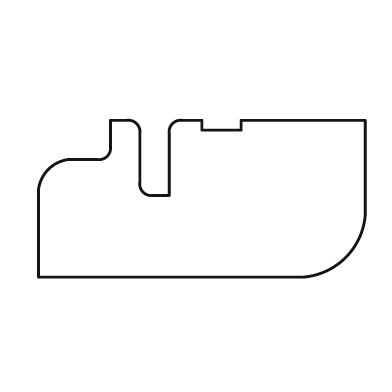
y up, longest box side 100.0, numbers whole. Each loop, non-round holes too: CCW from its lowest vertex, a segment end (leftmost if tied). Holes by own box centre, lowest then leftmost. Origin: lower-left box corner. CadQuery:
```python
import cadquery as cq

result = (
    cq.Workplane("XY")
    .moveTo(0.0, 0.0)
    .lineTo(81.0, 0.0)
    .threePointArc((94.0, 6.0), (100.0, 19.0))
    .lineTo(100.0, 48.0)
    .lineTo(62.0, 48.0)
    .lineTo(62.0, 45.0)
    .lineTo(50.0, 45.0)
    .lineTo(50.0, 48.0)
    .lineTo(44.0, 48.0)
    .threePointArc((41.0, 47.0), (40.0, 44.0))
    .lineTo(40.0, 25.0)
    .lineTo(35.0, 25.0)
    .threePointArc((32.0, 26.0), (31.0, 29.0))
    .lineTo(31.0, 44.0)
    .threePointArc((30.0, 47.0), (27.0, 48.0))
    .lineTo(22.0, 48.0)
    .lineTo(22.0, 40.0)
    .threePointArc((21.0, 37.0), (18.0, 36.0))
    .lineTo(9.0, 36.0)
    .threePointArc((3.0, 33.0), (0.0, 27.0))
    .close()
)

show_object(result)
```